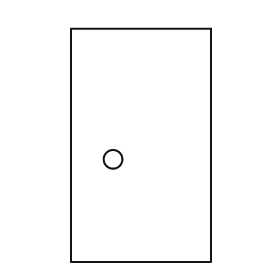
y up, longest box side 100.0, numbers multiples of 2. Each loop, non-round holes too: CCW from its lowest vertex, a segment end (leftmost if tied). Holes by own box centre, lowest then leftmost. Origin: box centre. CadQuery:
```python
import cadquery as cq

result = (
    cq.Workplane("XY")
    .moveTo(-30.0, -50.0)
    .lineTo(30.0, -50.0)
    .lineTo(30.0, 50.0)
    .lineTo(-30.0, 50.0)
    .close()
    .moveTo(-12.0, -6.0)
    .circle(4.0)
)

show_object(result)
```